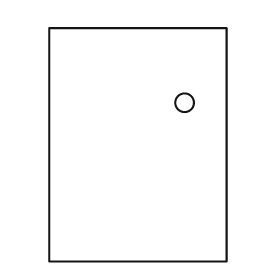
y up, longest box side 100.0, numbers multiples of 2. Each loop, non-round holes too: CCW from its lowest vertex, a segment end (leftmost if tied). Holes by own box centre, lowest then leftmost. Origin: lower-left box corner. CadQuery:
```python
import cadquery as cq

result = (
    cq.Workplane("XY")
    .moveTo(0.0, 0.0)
    .lineTo(76.0, 0.0)
    .lineTo(76.0, 100.0)
    .lineTo(0.0, 100.0)
    .close()
    .moveTo(58.0, 68.0)
    .circle(4.0)
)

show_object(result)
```